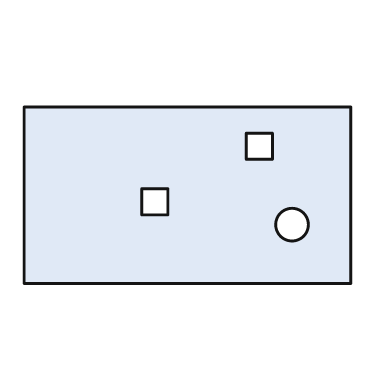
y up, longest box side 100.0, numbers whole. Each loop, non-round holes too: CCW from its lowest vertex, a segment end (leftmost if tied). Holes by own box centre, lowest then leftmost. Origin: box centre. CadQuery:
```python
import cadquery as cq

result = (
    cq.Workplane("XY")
    .moveTo(-50.0, -27.0)
    .lineTo(50.0, -27.0)
    .lineTo(50.0, 27.0)
    .lineTo(-50.0, 27.0)
    .close()
    .moveTo(32.0, -9.0)
    .circle(5.0)
    .moveTo(-14.0, -6.0)
    .lineTo(-6.0, -6.0)
    .lineTo(-6.0, 2.0)
    .lineTo(-14.0, 2.0)
    .close()
    .moveTo(18.0, 11.0)
    .lineTo(26.0, 11.0)
    .lineTo(26.0, 19.0)
    .lineTo(18.0, 19.0)
    .close()
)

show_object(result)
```